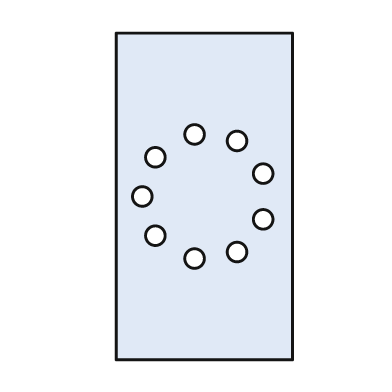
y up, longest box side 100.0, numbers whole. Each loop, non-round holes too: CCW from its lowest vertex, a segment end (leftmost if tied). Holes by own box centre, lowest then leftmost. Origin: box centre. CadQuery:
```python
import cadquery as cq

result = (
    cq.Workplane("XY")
    .moveTo(-27.0, -50.0)
    .lineTo(27.0, -50.0)
    .lineTo(27.0, 50.0)
    .lineTo(-27.0, 50.0)
    .close()
    .moveTo(-3.0, -19.0)
    .circle(3.0)
    .moveTo(10.0, -17.0)
    .circle(3.0)
    .moveTo(-15.0, -12.0)
    .circle(3.0)
    .moveTo(18.0, -7.0)
    .circle(3.0)
    .moveTo(-19.0, 0.0)
    .circle(3.0)
    .moveTo(18.0, 7.0)
    .circle(3.0)
    .moveTo(-15.0, 12.0)
    .circle(3.0)
    .moveTo(10.0, 17.0)
    .circle(3.0)
    .moveTo(-3.0, 19.0)
    .circle(3.0)
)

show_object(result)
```